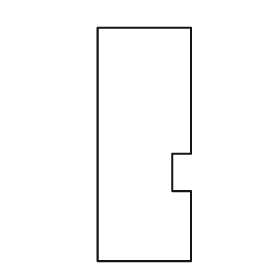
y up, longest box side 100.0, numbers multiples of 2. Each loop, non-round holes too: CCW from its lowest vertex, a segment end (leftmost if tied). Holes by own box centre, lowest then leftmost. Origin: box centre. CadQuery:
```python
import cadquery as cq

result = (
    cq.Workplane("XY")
    .moveTo(-20.0, -50.0)
    .lineTo(20.0, -50.0)
    .lineTo(20.0, -20.0)
    .lineTo(12.0, -20.0)
    .lineTo(12.0, -4.0)
    .lineTo(20.0, -4.0)
    .lineTo(20.0, 50.0)
    .lineTo(-20.0, 50.0)
    .close()
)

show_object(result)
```